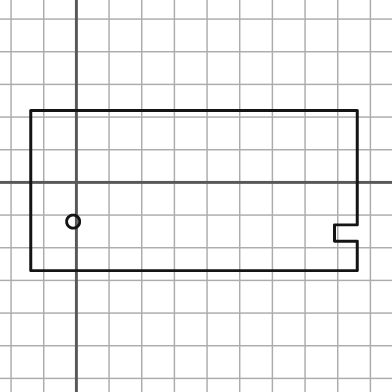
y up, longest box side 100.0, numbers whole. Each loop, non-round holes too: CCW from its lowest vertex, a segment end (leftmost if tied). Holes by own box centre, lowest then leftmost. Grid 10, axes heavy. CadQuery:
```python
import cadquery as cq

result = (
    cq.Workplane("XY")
    .moveTo(-14.0, -27.0)
    .lineTo(86.0, -27.0)
    .lineTo(86.0, -18.0)
    .lineTo(79.0, -18.0)
    .lineTo(79.0, -13.0)
    .lineTo(86.0, -13.0)
    .lineTo(86.0, 22.0)
    .lineTo(-14.0, 22.0)
    .close()
    .moveTo(-1.0, -12.0)
    .circle(2.0)
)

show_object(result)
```